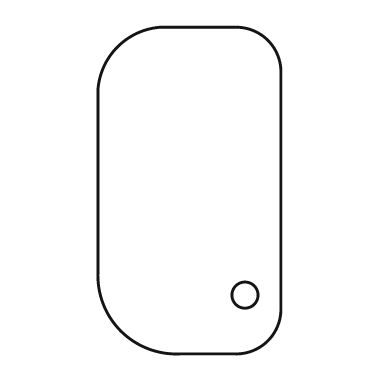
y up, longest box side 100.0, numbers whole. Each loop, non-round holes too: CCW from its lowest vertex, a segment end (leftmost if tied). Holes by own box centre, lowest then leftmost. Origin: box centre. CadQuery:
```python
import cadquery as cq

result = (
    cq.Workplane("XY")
    .moveTo(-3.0, -50.0)
    .lineTo(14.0, -50.0)
    .threePointArc((24.0, -46.0), (28.0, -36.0))
    .lineTo(28.0, 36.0)
    .threePointArc((24.0, 46.0), (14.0, 50.0))
    .lineTo(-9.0, 50.0)
    .threePointArc((-22.0, 44.0), (-28.0, 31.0))
    .lineTo(-28.0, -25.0)
    .threePointArc((-21.0, -43.0), (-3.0, -50.0))
    .close()
    .moveTo(17.0, -32.0)
    .circle(4.0)
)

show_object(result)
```